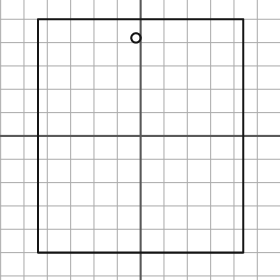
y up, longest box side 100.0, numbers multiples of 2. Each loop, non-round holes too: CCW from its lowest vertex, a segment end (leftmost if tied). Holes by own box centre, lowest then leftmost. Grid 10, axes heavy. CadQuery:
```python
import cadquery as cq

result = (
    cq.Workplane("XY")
    .moveTo(-44.0, -50.0)
    .lineTo(44.0, -50.0)
    .lineTo(44.0, 50.0)
    .lineTo(-44.0, 50.0)
    .close()
    .moveTo(-2.0, 42.0)
    .circle(2.0)
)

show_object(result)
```